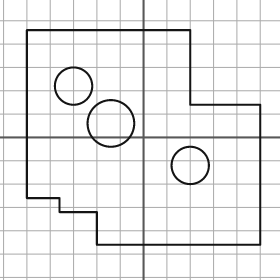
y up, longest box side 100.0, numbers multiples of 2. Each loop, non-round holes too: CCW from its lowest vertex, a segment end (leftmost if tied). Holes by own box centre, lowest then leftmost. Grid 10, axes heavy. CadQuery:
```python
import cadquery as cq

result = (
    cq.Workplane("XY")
    .moveTo(-20.0, -46.0)
    .lineTo(50.0, -46.0)
    .lineTo(50.0, 14.0)
    .lineTo(20.0, 14.0)
    .lineTo(20.0, 46.0)
    .lineTo(-50.0, 46.0)
    .lineTo(-50.0, -26.0)
    .lineTo(-36.0, -26.0)
    .lineTo(-36.0, -32.0)
    .lineTo(-20.0, -32.0)
    .close()
    .moveTo(20.0, -12.0)
    .circle(8.0)
    .moveTo(-14.0, 6.0)
    .circle(10.0)
    .moveTo(-30.0, 22.0)
    .circle(8.0)
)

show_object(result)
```